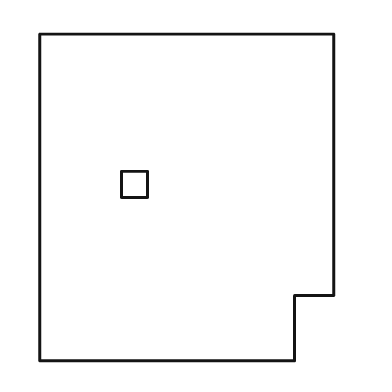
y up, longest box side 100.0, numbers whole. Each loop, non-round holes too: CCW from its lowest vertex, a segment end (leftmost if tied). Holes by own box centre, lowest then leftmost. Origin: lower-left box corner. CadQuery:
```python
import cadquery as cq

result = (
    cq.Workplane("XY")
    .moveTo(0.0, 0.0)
    .lineTo(78.0, 0.0)
    .lineTo(78.0, 20.0)
    .lineTo(90.0, 20.0)
    .lineTo(90.0, 100.0)
    .lineTo(0.0, 100.0)
    .close()
    .moveTo(25.0, 50.0)
    .lineTo(33.0, 50.0)
    .lineTo(33.0, 58.0)
    .lineTo(25.0, 58.0)
    .close()
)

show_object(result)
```